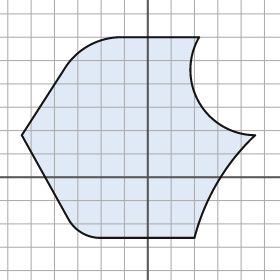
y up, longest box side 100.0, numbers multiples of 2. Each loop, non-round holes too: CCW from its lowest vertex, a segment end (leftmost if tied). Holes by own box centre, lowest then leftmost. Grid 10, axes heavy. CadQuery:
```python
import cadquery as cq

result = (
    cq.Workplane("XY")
    .moveTo(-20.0, -26.0)
    .lineTo(20.0, -26.0)
    .threePointArc((30.0, -2.0), (46.0, 18.0))
    .threePointArc((22.0, 32.0), (22.0, 60.0))
    .lineTo(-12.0, 60.0)
    .threePointArc((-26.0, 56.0), (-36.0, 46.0))
    .lineTo(-54.0, 18.0)
    .lineTo(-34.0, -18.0)
    .threePointArc((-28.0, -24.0), (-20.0, -26.0))
    .close()
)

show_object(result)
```